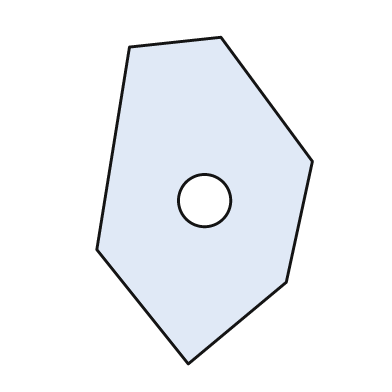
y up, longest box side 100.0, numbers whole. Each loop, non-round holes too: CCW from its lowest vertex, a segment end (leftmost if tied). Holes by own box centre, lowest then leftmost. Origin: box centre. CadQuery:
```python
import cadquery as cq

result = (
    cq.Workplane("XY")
    .moveTo(-5.0, -50.0)
    .lineTo(25.0, -25.0)
    .lineTo(33.0, 12.0)
    .lineTo(5.0, 50.0)
    .lineTo(-23.0, 47.0)
    .lineTo(-33.0, -15.0)
    .close()
    .moveTo(0.0, 0.0)
    .circle(8.0)
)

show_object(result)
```